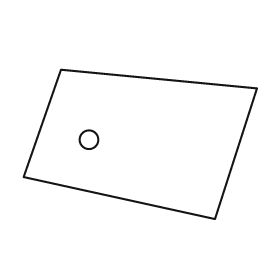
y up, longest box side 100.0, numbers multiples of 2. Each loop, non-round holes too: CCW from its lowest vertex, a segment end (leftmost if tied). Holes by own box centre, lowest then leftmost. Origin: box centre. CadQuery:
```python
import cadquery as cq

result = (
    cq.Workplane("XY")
    .moveTo(32.0, -32.0)
    .lineTo(50.0, 24.0)
    .lineTo(-34.0, 32.0)
    .lineTo(-50.0, -14.0)
    .close()
    .moveTo(-22.0, 2.0)
    .circle(4.0)
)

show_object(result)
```